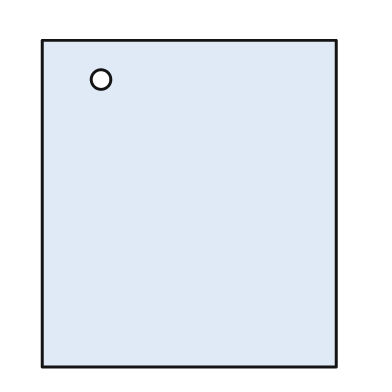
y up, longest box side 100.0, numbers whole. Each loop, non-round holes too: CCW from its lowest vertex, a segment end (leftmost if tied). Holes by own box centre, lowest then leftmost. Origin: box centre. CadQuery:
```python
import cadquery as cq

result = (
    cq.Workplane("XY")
    .moveTo(-45.0, -50.0)
    .lineTo(45.0, -50.0)
    .lineTo(45.0, 50.0)
    .lineTo(-45.0, 50.0)
    .close()
    .moveTo(-27.0, 38.0)
    .circle(3.0)
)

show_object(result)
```